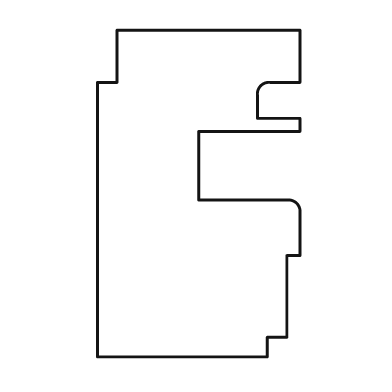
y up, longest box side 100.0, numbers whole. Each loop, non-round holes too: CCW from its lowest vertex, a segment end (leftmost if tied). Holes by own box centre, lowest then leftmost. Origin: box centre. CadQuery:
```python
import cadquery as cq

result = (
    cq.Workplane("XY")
    .moveTo(-31.0, -50.0)
    .lineTo(21.0, -50.0)
    .lineTo(21.0, -44.0)
    .lineTo(27.0, -44.0)
    .lineTo(27.0, -19.0)
    .lineTo(31.0, -19.0)
    .lineTo(31.0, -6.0)
    .threePointArc((30.0, -3.0), (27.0, -2.0))
    .lineTo(0.0, -2.0)
    .lineTo(0.0, 19.0)
    .lineTo(31.0, 19.0)
    .lineTo(31.0, 23.0)
    .lineTo(18.0, 23.0)
    .lineTo(18.0, 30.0)
    .threePointArc((19.0, 33.0), (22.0, 34.0))
    .lineTo(31.0, 34.0)
    .lineTo(31.0, 50.0)
    .lineTo(-25.0, 50.0)
    .lineTo(-25.0, 34.0)
    .lineTo(-31.0, 34.0)
    .close()
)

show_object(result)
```